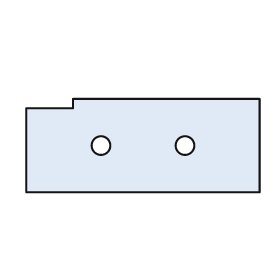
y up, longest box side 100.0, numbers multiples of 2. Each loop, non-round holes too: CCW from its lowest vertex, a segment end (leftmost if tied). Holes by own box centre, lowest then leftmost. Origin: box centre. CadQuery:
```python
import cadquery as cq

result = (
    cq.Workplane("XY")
    .moveTo(-50.0, -20.0)
    .lineTo(50.0, -20.0)
    .lineTo(50.0, 20.0)
    .lineTo(-30.0, 20.0)
    .lineTo(-30.0, 16.0)
    .lineTo(-50.0, 16.0)
    .close()
    .moveTo(-18.0, 0.0)
    .circle(4.0)
    .moveTo(18.0, 0.0)
    .circle(4.0)
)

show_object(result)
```